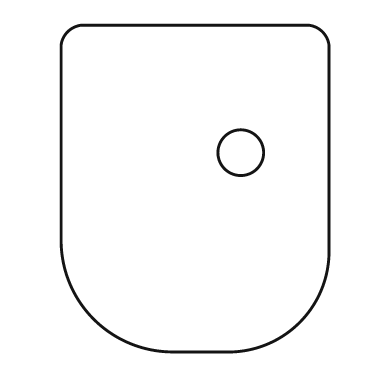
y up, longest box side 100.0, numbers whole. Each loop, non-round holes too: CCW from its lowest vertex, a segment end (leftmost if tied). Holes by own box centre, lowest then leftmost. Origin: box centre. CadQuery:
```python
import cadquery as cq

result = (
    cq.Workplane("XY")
    .moveTo(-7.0, -50.0)
    .lineTo(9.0, -50.0)
    .threePointArc((32.0, -41.0), (41.0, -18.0))
    .lineTo(41.0, 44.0)
    .threePointArc((39.0, 48.0), (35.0, 50.0))
    .lineTo(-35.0, 50.0)
    .threePointArc((-39.0, 48.0), (-41.0, 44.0))
    .lineTo(-41.0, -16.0)
    .threePointArc((-31.0, -40.0), (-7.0, -50.0))
    .close()
    .moveTo(14.0, 11.0)
    .circle(7.0)
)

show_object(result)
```